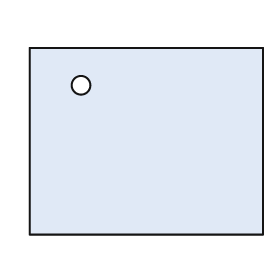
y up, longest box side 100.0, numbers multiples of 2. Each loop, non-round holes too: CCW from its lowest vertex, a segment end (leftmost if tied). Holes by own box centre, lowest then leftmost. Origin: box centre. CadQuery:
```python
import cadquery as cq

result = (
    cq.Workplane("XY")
    .moveTo(-50.0, -40.0)
    .lineTo(50.0, -40.0)
    .lineTo(50.0, 40.0)
    .lineTo(-50.0, 40.0)
    .close()
    .moveTo(-28.0, 24.0)
    .circle(4.0)
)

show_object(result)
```